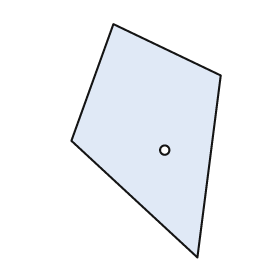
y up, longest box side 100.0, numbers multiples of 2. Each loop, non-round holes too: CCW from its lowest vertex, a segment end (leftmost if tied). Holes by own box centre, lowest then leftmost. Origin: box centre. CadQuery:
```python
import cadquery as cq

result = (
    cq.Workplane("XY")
    .moveTo(22.0, -50.0)
    .lineTo(32.0, 28.0)
    .lineTo(-14.0, 50.0)
    .lineTo(-32.0, 0.0)
    .close()
    .moveTo(8.0, -4.0)
    .circle(2.0)
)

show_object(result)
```